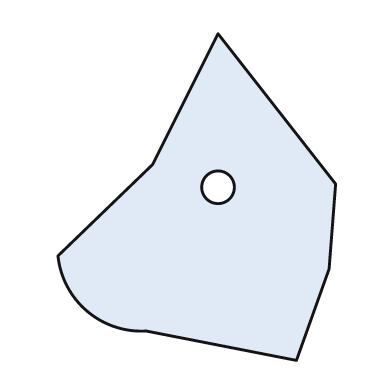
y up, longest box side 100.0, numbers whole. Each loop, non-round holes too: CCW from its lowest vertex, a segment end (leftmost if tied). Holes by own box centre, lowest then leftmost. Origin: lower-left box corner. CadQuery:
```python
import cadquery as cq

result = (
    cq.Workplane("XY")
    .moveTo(73.0, 0.0)
    .lineTo(83.0, 28.0)
    .lineTo(85.0, 54.0)
    .lineTo(49.0, 100.0)
    .lineTo(29.0, 60.0)
    .lineTo(0.0, 32.0)
    .threePointArc((9.0, 15.0), (27.0, 9.0))
    .close()
    .moveTo(49.0, 53.0)
    .circle(5.0)
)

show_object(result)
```